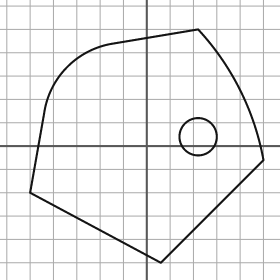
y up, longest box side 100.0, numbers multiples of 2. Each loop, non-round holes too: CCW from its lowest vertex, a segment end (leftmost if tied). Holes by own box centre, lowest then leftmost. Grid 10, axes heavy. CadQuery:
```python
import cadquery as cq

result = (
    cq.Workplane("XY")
    .moveTo(6.0, -50.0)
    .lineTo(50.0, -6.0)
    .threePointArc((40.0, 24.0), (22.0, 50.0))
    .lineTo(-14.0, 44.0)
    .threePointArc((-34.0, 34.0), (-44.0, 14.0))
    .lineTo(-50.0, -20.0)
    .close()
    .moveTo(22.0, 4.0)
    .circle(8.0)
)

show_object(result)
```